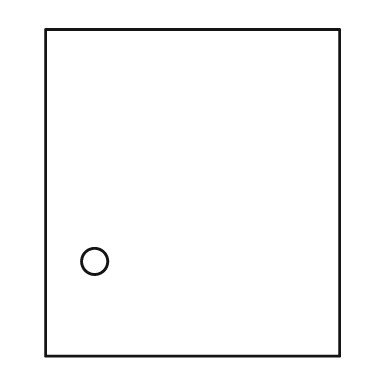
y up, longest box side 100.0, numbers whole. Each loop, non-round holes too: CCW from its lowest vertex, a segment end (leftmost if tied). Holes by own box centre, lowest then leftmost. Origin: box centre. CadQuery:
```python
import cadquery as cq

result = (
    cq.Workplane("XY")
    .moveTo(-45.0, -50.0)
    .lineTo(45.0, -50.0)
    .lineTo(45.0, 50.0)
    .lineTo(-45.0, 50.0)
    .close()
    .moveTo(-30.0, -21.0)
    .circle(4.0)
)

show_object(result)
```